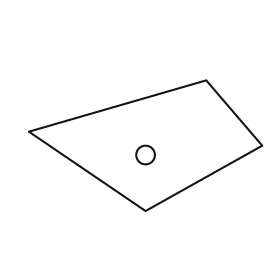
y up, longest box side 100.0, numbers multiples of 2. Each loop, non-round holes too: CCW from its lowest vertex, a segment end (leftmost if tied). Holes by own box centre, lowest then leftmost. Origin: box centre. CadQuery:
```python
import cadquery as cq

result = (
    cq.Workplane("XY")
    .moveTo(0.0, -28.0)
    .lineTo(50.0, 0.0)
    .lineTo(26.0, 28.0)
    .lineTo(-50.0, 6.0)
    .close()
    .moveTo(0.0, -4.0)
    .circle(4.0)
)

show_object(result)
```